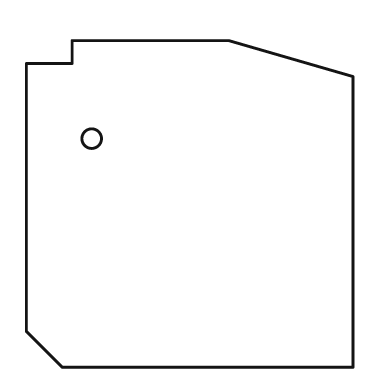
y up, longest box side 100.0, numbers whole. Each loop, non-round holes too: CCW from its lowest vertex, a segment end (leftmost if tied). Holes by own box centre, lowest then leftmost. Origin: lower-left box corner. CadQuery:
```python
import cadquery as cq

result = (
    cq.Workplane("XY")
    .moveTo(11.0, 0.0)
    .lineTo(100.0, 0.0)
    .lineTo(100.0, 89.0)
    .lineTo(62.0, 100.0)
    .lineTo(14.0, 100.0)
    .lineTo(14.0, 93.0)
    .lineTo(0.0, 93.0)
    .lineTo(0.0, 11.0)
    .close()
    .moveTo(20.0, 70.0)
    .circle(3.0)
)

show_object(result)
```